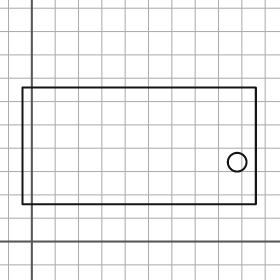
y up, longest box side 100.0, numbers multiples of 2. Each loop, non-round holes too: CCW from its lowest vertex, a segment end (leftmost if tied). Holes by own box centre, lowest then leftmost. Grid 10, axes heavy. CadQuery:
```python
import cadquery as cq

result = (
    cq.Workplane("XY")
    .moveTo(-4.0, 16.0)
    .lineTo(96.0, 16.0)
    .lineTo(96.0, 66.0)
    .lineTo(-4.0, 66.0)
    .close()
    .moveTo(88.0, 34.0)
    .circle(4.0)
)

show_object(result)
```